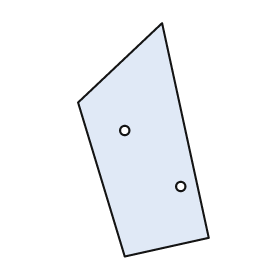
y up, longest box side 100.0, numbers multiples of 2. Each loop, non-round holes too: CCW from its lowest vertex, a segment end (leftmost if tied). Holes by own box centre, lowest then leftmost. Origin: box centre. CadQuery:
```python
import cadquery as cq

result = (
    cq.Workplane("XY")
    .moveTo(-8.0, -50.0)
    .lineTo(28.0, -42.0)
    .lineTo(8.0, 50.0)
    .lineTo(-28.0, 16.0)
    .close()
    .moveTo(16.0, -20.0)
    .circle(2.0)
    .moveTo(-8.0, 4.0)
    .circle(2.0)
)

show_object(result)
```